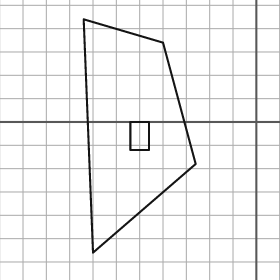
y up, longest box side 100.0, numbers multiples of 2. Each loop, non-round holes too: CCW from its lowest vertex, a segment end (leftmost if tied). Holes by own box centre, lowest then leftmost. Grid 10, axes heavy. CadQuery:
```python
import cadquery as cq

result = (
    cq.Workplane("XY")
    .moveTo(-70.0, -56.0)
    .lineTo(-26.0, -18.0)
    .lineTo(-40.0, 34.0)
    .lineTo(-74.0, 44.0)
    .close()
    .moveTo(-54.0, -12.0)
    .lineTo(-46.0, -12.0)
    .lineTo(-46.0, 0.0)
    .lineTo(-54.0, 0.0)
    .close()
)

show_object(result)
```